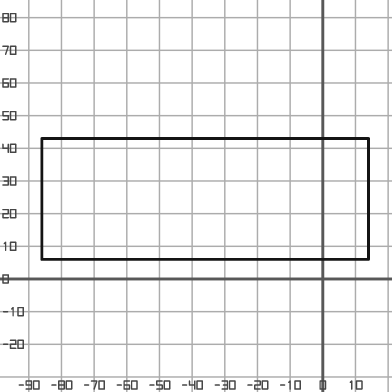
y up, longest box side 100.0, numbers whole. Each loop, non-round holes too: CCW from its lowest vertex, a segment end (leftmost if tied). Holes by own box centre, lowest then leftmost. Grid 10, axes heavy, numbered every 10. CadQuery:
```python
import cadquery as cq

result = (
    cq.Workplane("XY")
    .moveTo(-86.0, 6.0)
    .lineTo(14.0, 6.0)
    .lineTo(14.0, 43.0)
    .lineTo(-86.0, 43.0)
    .close()
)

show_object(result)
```